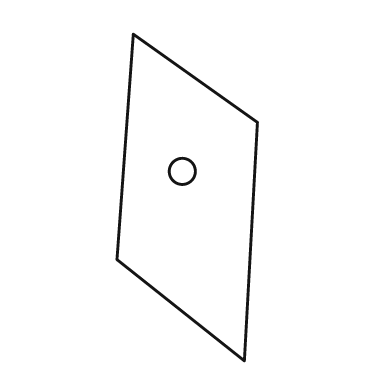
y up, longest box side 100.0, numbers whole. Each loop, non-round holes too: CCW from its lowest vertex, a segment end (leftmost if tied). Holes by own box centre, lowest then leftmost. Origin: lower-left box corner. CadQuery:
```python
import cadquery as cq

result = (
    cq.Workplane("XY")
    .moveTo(39.0, 0.0)
    .lineTo(43.0, 73.0)
    .lineTo(5.0, 100.0)
    .lineTo(0.0, 31.0)
    .close()
    .moveTo(20.0, 58.0)
    .circle(4.0)
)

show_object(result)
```